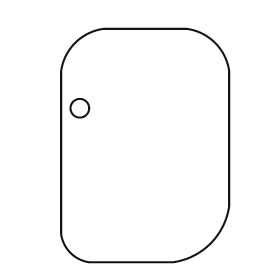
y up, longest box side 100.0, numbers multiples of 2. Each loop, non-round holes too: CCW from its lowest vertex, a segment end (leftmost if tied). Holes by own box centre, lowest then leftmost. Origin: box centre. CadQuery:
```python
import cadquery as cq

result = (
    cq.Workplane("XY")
    .moveTo(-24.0, -50.0)
    .lineTo(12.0, -50.0)
    .threePointArc((28.0, -42.0), (36.0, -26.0))
    .lineTo(36.0, 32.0)
    .threePointArc((30.0, 44.0), (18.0, 50.0))
    .lineTo(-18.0, 50.0)
    .threePointArc((-30.0, 44.0), (-36.0, 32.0))
    .lineTo(-36.0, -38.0)
    .threePointArc((-32.0, -46.0), (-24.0, -50.0))
    .close()
    .moveTo(-28.0, 16.0)
    .circle(4.0)
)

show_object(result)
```